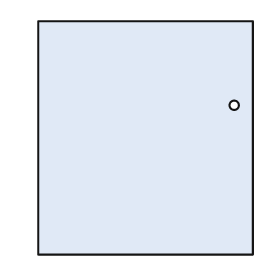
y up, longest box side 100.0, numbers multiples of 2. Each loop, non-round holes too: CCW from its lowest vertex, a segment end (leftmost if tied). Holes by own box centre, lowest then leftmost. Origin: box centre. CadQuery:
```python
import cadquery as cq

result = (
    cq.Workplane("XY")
    .moveTo(-46.0, -50.0)
    .lineTo(46.0, -50.0)
    .lineTo(46.0, 50.0)
    .lineTo(-46.0, 50.0)
    .close()
    .moveTo(38.0, 14.0)
    .circle(2.0)
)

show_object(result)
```